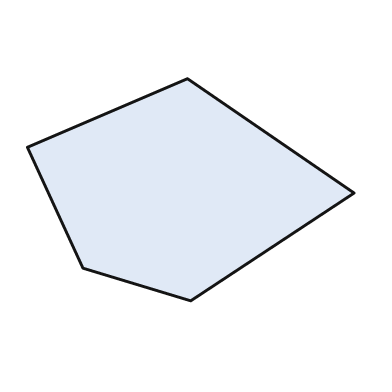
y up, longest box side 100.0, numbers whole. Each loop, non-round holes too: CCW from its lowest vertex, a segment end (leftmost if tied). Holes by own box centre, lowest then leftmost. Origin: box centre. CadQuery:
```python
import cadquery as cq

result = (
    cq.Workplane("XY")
    .moveTo(0.0, -34.0)
    .lineTo(50.0, -1.0)
    .lineTo(-1.0, 34.0)
    .lineTo(-50.0, 13.0)
    .lineTo(-33.0, -24.0)
    .close()
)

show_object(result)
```